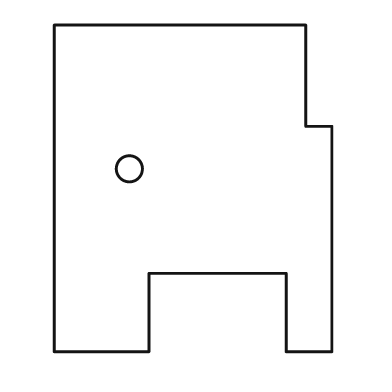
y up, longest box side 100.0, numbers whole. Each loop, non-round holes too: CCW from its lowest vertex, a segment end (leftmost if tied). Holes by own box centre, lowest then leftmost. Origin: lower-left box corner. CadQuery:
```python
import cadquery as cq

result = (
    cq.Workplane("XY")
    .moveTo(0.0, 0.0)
    .lineTo(29.0, 0.0)
    .lineTo(29.0, 24.0)
    .lineTo(71.0, 24.0)
    .lineTo(71.0, 0.0)
    .lineTo(85.0, 0.0)
    .lineTo(85.0, 69.0)
    .lineTo(77.0, 69.0)
    .lineTo(77.0, 100.0)
    .lineTo(0.0, 100.0)
    .close()
    .moveTo(23.0, 56.0)
    .circle(4.0)
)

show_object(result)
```